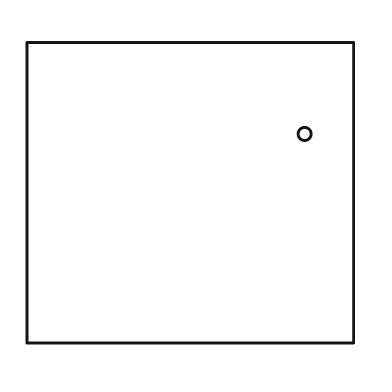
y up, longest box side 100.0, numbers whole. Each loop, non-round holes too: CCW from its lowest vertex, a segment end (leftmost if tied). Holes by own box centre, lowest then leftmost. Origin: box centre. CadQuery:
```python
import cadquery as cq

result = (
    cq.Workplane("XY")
    .moveTo(-50.0, -46.0)
    .lineTo(50.0, -46.0)
    .lineTo(50.0, 46.0)
    .lineTo(-50.0, 46.0)
    .close()
    .moveTo(35.0, 18.0)
    .circle(2.0)
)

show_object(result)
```